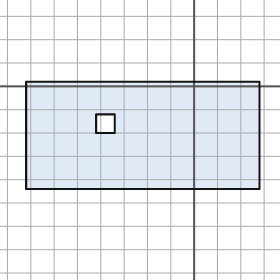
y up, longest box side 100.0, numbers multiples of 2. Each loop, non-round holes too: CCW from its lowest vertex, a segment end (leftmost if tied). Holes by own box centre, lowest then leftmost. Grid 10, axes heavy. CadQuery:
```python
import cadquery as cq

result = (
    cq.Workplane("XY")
    .moveTo(-72.0, -44.0)
    .lineTo(28.0, -44.0)
    .lineTo(28.0, 2.0)
    .lineTo(-72.0, 2.0)
    .close()
    .moveTo(-42.0, -20.0)
    .lineTo(-34.0, -20.0)
    .lineTo(-34.0, -12.0)
    .lineTo(-42.0, -12.0)
    .close()
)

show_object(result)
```